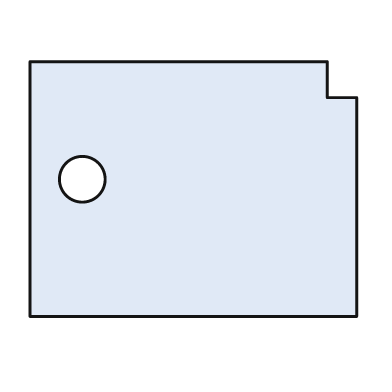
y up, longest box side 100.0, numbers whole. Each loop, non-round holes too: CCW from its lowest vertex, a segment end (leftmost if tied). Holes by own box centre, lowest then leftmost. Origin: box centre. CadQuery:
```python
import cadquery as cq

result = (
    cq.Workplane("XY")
    .moveTo(-50.0, -39.0)
    .lineTo(50.0, -39.0)
    .lineTo(50.0, 28.0)
    .lineTo(41.0, 28.0)
    .lineTo(41.0, 39.0)
    .lineTo(-50.0, 39.0)
    .close()
    .moveTo(-34.0, 3.0)
    .circle(7.0)
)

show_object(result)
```